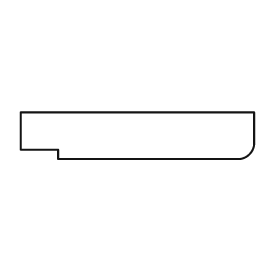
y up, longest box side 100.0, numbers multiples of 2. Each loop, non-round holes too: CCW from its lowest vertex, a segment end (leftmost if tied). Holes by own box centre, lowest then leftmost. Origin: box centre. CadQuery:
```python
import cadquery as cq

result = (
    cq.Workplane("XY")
    .moveTo(-34.0, -10.0)
    .lineTo(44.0, -10.0)
    .threePointArc((48.0, -8.0), (50.0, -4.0))
    .lineTo(50.0, 10.0)
    .lineTo(-50.0, 10.0)
    .lineTo(-50.0, -6.0)
    .lineTo(-34.0, -6.0)
    .close()
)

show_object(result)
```